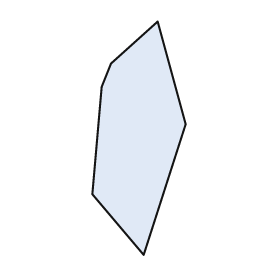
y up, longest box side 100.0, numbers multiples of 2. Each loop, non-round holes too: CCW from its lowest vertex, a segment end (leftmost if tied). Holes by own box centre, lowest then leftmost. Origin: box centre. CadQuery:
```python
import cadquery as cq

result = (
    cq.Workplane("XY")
    .moveTo(2.0, -50.0)
    .lineTo(20.0, 6.0)
    .lineTo(8.0, 50.0)
    .lineTo(-12.0, 32.0)
    .lineTo(-16.0, 22.0)
    .lineTo(-20.0, -24.0)
    .close()
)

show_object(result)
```